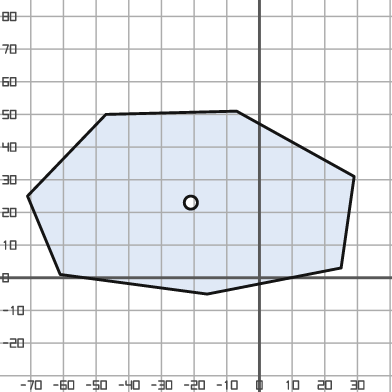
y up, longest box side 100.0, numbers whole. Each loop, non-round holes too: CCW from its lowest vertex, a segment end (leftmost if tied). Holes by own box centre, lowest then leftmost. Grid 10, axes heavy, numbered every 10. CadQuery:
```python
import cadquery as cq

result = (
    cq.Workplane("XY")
    .moveTo(-16.0, -5.0)
    .lineTo(25.0, 3.0)
    .lineTo(29.0, 31.0)
    .lineTo(-7.0, 51.0)
    .lineTo(-47.0, 50.0)
    .lineTo(-71.0, 25.0)
    .lineTo(-61.0, 1.0)
    .close()
    .moveTo(-21.0, 23.0)
    .circle(2.0)
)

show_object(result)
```